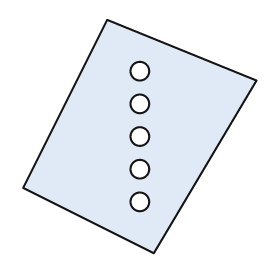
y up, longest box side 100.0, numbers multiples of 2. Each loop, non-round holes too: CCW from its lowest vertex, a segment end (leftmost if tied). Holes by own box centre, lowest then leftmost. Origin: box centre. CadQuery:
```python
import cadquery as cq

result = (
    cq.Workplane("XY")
    .moveTo(6.0, -50.0)
    .lineTo(50.0, 24.0)
    .lineTo(-14.0, 50.0)
    .lineTo(-50.0, -22.0)
    .close()
    .moveTo(0.0, -28.0)
    .circle(4.0)
    .moveTo(0.0, -14.0)
    .circle(4.0)
    .moveTo(0.0, 0.0)
    .circle(4.0)
    .moveTo(0.0, 14.0)
    .circle(4.0)
    .moveTo(0.0, 28.0)
    .circle(4.0)
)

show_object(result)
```